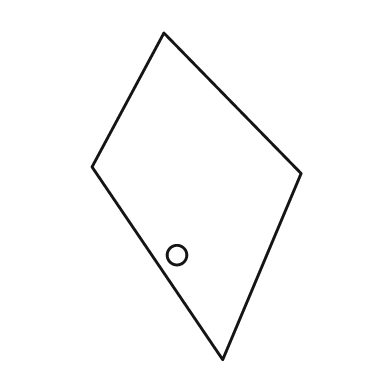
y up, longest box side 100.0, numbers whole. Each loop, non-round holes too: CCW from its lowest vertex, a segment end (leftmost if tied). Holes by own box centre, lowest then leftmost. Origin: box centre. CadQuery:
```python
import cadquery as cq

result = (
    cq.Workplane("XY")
    .moveTo(8.0, -50.0)
    .lineTo(32.0, 7.0)
    .lineTo(-10.0, 50.0)
    .lineTo(-32.0, 9.0)
    .close()
    .moveTo(-6.0, -18.0)
    .circle(3.0)
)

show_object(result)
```